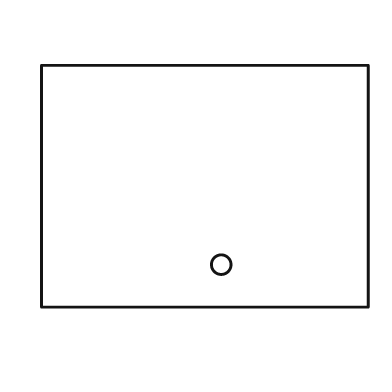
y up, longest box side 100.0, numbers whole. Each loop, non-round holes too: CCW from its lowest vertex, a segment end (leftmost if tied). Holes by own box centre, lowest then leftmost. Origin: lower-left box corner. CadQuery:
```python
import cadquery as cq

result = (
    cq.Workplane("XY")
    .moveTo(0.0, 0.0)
    .lineTo(100.0, 0.0)
    .lineTo(100.0, 74.0)
    .lineTo(0.0, 74.0)
    .close()
    .moveTo(55.0, 13.0)
    .circle(3.0)
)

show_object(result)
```